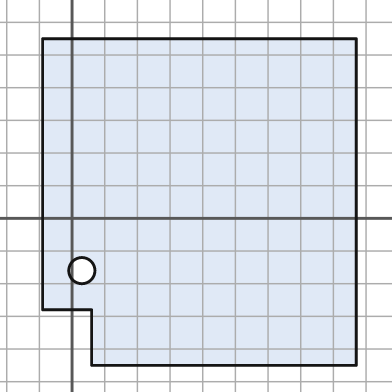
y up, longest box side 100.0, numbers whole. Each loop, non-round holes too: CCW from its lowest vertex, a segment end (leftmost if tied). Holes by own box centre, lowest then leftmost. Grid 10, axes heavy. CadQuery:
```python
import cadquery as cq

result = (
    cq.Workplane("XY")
    .moveTo(6.0, -45.0)
    .lineTo(87.0, -45.0)
    .lineTo(87.0, 55.0)
    .lineTo(-9.0, 55.0)
    .lineTo(-9.0, -28.0)
    .lineTo(6.0, -28.0)
    .close()
    .moveTo(3.0, -16.0)
    .circle(4.0)
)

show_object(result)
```